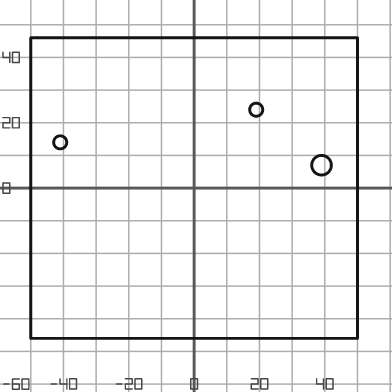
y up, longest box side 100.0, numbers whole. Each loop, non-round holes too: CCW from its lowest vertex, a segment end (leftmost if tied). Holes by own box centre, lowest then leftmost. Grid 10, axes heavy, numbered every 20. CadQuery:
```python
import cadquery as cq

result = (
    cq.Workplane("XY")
    .moveTo(-50.0, -46.0)
    .lineTo(50.0, -46.0)
    .lineTo(50.0, 46.0)
    .lineTo(-50.0, 46.0)
    .close()
    .moveTo(39.0, 7.0)
    .circle(3.0)
    .moveTo(-41.0, 14.0)
    .circle(2.0)
    .moveTo(19.0, 24.0)
    .circle(2.0)
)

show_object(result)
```